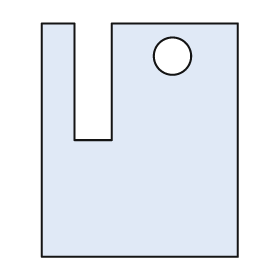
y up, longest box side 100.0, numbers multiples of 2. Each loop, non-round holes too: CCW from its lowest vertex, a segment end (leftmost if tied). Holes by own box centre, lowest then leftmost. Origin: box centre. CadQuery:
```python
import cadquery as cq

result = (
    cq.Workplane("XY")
    .moveTo(-42.0, -50.0)
    .lineTo(42.0, -50.0)
    .lineTo(42.0, 50.0)
    .lineTo(-12.0, 50.0)
    .lineTo(-12.0, 0.0)
    .lineTo(-28.0, 0.0)
    .lineTo(-28.0, 50.0)
    .lineTo(-42.0, 50.0)
    .close()
    .moveTo(14.0, 36.0)
    .circle(8.0)
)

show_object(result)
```